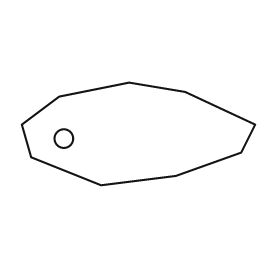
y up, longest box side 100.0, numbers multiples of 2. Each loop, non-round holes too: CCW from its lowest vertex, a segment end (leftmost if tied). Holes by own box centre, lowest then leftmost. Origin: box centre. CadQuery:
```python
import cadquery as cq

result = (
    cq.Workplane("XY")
    .moveTo(-16.0, -22.0)
    .lineTo(16.0, -18.0)
    .lineTo(44.0, -8.0)
    .lineTo(50.0, 4.0)
    .lineTo(20.0, 18.0)
    .lineTo(-4.0, 22.0)
    .lineTo(-34.0, 16.0)
    .lineTo(-50.0, 4.0)
    .lineTo(-46.0, -10.0)
    .close()
    .moveTo(-32.0, -2.0)
    .circle(4.0)
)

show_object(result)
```